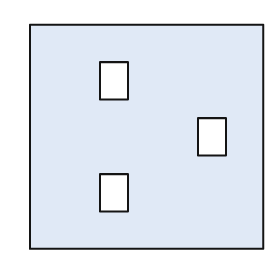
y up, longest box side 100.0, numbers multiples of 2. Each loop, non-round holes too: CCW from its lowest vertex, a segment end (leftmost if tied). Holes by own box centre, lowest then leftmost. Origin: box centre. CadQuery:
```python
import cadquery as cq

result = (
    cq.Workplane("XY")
    .moveTo(-50.0, -48.0)
    .lineTo(50.0, -48.0)
    .lineTo(50.0, 48.0)
    .lineTo(-50.0, 48.0)
    .close()
    .moveTo(-20.0, -32.0)
    .lineTo(-8.0, -32.0)
    .lineTo(-8.0, -16.0)
    .lineTo(-20.0, -16.0)
    .close()
    .moveTo(22.0, -8.0)
    .lineTo(34.0, -8.0)
    .lineTo(34.0, 8.0)
    .lineTo(22.0, 8.0)
    .close()
    .moveTo(-20.0, 16.0)
    .lineTo(-8.0, 16.0)
    .lineTo(-8.0, 32.0)
    .lineTo(-20.0, 32.0)
    .close()
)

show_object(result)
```